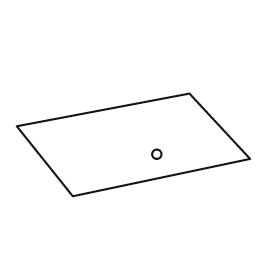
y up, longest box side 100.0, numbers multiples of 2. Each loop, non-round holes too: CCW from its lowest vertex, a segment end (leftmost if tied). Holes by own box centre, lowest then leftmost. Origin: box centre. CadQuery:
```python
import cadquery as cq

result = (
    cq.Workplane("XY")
    .moveTo(-26.0, -22.0)
    .lineTo(50.0, -6.0)
    .lineTo(24.0, 22.0)
    .lineTo(-50.0, 8.0)
    .close()
    .moveTo(10.0, -4.0)
    .circle(2.0)
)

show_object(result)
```